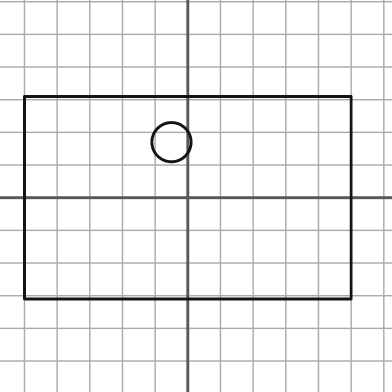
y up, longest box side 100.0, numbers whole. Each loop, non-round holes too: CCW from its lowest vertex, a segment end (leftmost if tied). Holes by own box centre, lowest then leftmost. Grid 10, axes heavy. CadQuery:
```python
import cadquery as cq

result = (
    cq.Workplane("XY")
    .moveTo(-50.0, -31.0)
    .lineTo(50.0, -31.0)
    .lineTo(50.0, 31.0)
    .lineTo(-50.0, 31.0)
    .close()
    .moveTo(-5.0, 17.0)
    .circle(6.0)
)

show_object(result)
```